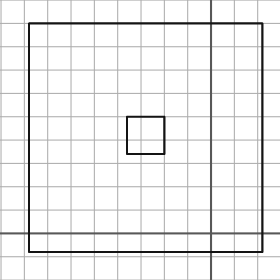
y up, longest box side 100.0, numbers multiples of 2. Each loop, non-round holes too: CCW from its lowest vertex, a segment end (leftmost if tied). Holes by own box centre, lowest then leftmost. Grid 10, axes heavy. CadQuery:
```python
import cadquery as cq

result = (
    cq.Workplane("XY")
    .moveTo(-78.0, -8.0)
    .lineTo(22.0, -8.0)
    .lineTo(22.0, 90.0)
    .lineTo(-78.0, 90.0)
    .close()
    .moveTo(-36.0, 34.0)
    .lineTo(-20.0, 34.0)
    .lineTo(-20.0, 50.0)
    .lineTo(-36.0, 50.0)
    .close()
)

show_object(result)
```